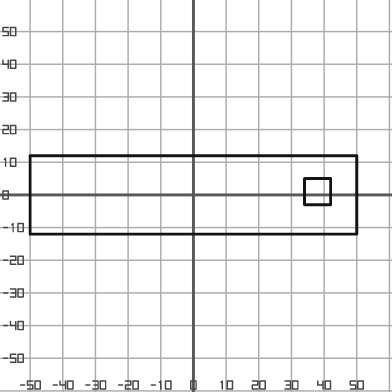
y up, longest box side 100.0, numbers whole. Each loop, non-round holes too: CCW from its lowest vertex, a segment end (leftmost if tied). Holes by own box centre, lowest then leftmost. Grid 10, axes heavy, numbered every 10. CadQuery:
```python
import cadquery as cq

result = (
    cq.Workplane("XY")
    .moveTo(-50.0, -12.0)
    .lineTo(50.0, -12.0)
    .lineTo(50.0, 12.0)
    .lineTo(-50.0, 12.0)
    .close()
    .moveTo(34.0, -3.0)
    .lineTo(42.0, -3.0)
    .lineTo(42.0, 5.0)
    .lineTo(34.0, 5.0)
    .close()
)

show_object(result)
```